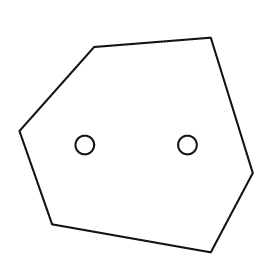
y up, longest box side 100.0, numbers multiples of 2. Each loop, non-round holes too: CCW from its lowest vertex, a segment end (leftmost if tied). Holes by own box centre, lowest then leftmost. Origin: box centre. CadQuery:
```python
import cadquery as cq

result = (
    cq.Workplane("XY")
    .moveTo(32.0, -46.0)
    .lineTo(50.0, -12.0)
    .lineTo(32.0, 46.0)
    .lineTo(-18.0, 42.0)
    .lineTo(-50.0, 6.0)
    .lineTo(-36.0, -34.0)
    .close()
    .moveTo(-22.0, 0.0)
    .circle(4.0)
    .moveTo(22.0, 0.0)
    .circle(4.0)
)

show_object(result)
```